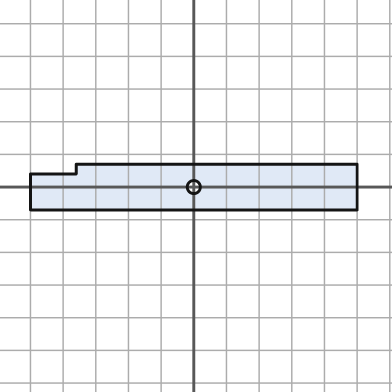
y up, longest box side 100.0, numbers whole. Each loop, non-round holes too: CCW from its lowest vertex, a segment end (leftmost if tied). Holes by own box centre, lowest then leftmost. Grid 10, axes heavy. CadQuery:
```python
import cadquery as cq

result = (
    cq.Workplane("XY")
    .moveTo(-50.0, -7.0)
    .lineTo(50.0, -7.0)
    .lineTo(50.0, 7.0)
    .lineTo(-36.0, 7.0)
    .lineTo(-36.0, 4.0)
    .lineTo(-50.0, 4.0)
    .close()
    .moveTo(0.0, 0.0)
    .circle(2.0)
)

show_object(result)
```